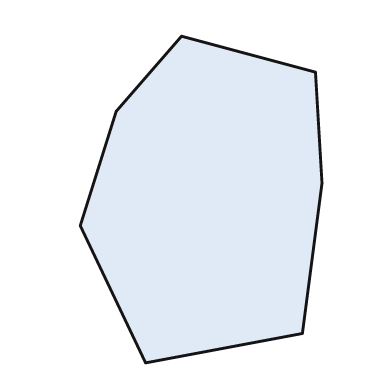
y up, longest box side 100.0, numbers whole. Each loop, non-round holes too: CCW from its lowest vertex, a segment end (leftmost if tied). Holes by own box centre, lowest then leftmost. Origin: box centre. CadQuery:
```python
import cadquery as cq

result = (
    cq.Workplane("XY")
    .moveTo(-17.0, -50.0)
    .lineTo(31.0, -41.0)
    .lineTo(37.0, 5.0)
    .lineTo(35.0, 39.0)
    .lineTo(-6.0, 50.0)
    .lineTo(-26.0, 27.0)
    .lineTo(-37.0, -8.0)
    .close()
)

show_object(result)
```